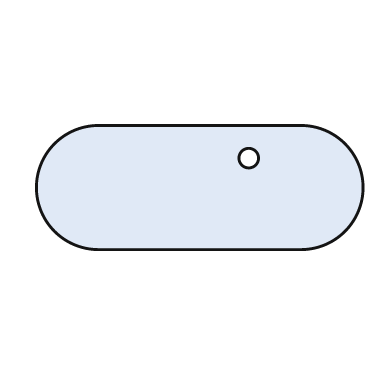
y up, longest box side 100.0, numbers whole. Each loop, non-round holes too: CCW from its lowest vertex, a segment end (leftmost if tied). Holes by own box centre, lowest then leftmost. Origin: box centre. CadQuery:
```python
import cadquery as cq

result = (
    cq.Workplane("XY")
    .moveTo(-31.0, -19.0)
    .lineTo(31.0, -19.0)
    .threePointArc((50.0, 0.0), (31.0, 19.0))
    .lineTo(-31.0, 19.0)
    .threePointArc((-50.0, 0.0), (-31.0, -19.0))
    .close()
    .moveTo(15.0, 9.0)
    .circle(3.0)
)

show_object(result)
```